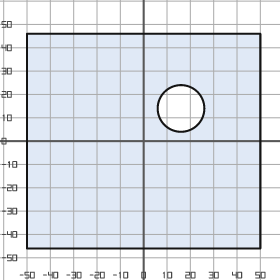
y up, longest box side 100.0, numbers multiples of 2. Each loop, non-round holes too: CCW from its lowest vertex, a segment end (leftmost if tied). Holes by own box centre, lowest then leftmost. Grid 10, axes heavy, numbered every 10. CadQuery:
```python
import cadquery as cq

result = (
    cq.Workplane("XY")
    .moveTo(-50.0, -46.0)
    .lineTo(50.0, -46.0)
    .lineTo(50.0, 46.0)
    .lineTo(-50.0, 46.0)
    .close()
    .moveTo(16.0, 14.0)
    .circle(10.0)
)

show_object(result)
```